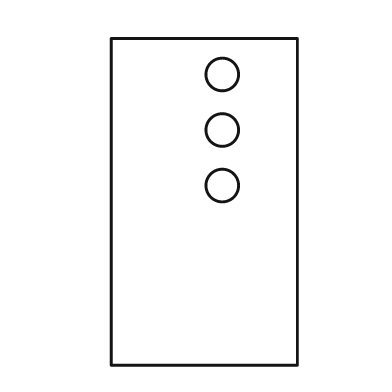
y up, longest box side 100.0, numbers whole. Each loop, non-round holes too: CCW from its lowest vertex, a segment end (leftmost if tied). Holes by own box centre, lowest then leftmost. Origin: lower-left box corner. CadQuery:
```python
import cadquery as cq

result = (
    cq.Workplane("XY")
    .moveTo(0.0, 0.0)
    .lineTo(57.0, 0.0)
    .lineTo(57.0, 100.0)
    .lineTo(0.0, 100.0)
    .close()
    .moveTo(34.0, 55.0)
    .circle(5.0)
    .moveTo(34.0, 72.0)
    .circle(5.0)
    .moveTo(34.0, 89.0)
    .circle(5.0)
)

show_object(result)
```